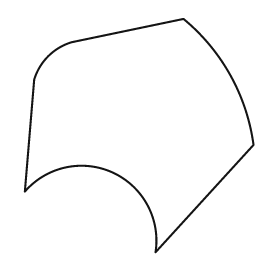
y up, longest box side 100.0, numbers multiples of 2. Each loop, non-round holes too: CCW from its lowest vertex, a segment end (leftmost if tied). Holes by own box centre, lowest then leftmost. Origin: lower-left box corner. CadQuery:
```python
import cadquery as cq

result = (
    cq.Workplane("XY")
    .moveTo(56.0, 0.0)
    .lineTo(98.0, 46.0)
    .threePointArc((88.0, 76.0), (68.0, 100.0))
    .lineTo(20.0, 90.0)
    .threePointArc((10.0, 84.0), (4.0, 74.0))
    .lineTo(0.0, 26.0)
    .threePointArc((38.0, 34.0), (56.0, 0.0))
    .close()
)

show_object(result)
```